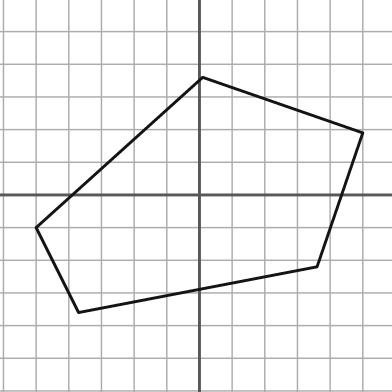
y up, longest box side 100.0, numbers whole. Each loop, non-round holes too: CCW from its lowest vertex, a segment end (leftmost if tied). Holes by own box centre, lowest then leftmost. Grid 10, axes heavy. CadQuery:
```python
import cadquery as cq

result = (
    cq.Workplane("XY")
    .moveTo(-37.0, -36.0)
    .lineTo(36.0, -22.0)
    .lineTo(50.0, 19.0)
    .lineTo(1.0, 36.0)
    .lineTo(-50.0, -10.0)
    .close()
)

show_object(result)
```